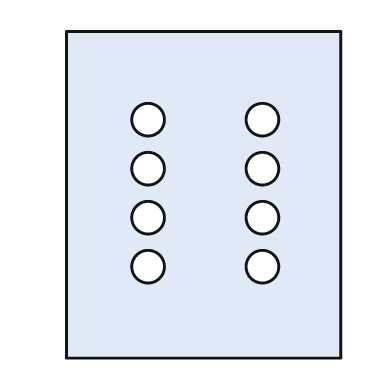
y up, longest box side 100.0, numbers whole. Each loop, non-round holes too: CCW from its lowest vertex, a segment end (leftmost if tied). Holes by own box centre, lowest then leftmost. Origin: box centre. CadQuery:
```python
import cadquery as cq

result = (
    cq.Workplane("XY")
    .moveTo(-42.0, -50.0)
    .lineTo(42.0, -50.0)
    .lineTo(42.0, 50.0)
    .lineTo(-42.0, 50.0)
    .close()
    .moveTo(-17.0, -22.0)
    .circle(5.0)
    .moveTo(18.0, -22.0)
    .circle(5.0)
    .moveTo(-17.0, -7.0)
    .circle(5.0)
    .moveTo(18.0, -7.0)
    .circle(5.0)
    .moveTo(-17.0, 8.0)
    .circle(5.0)
    .moveTo(18.0, 8.0)
    .circle(5.0)
    .moveTo(-17.0, 23.0)
    .circle(5.0)
    .moveTo(18.0, 23.0)
    .circle(5.0)
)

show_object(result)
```